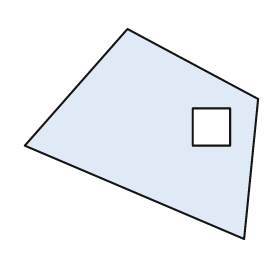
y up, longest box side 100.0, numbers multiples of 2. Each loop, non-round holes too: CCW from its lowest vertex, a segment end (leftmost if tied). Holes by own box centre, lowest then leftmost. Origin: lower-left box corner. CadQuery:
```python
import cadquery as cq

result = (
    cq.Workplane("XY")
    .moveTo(94.0, 0.0)
    .lineTo(100.0, 60.0)
    .lineTo(44.0, 90.0)
    .lineTo(0.0, 40.0)
    .close()
    .moveTo(72.0, 40.0)
    .lineTo(88.0, 40.0)
    .lineTo(88.0, 56.0)
    .lineTo(72.0, 56.0)
    .close()
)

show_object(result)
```